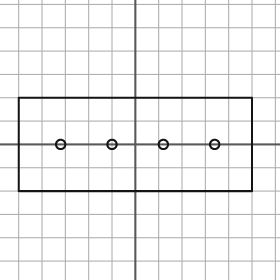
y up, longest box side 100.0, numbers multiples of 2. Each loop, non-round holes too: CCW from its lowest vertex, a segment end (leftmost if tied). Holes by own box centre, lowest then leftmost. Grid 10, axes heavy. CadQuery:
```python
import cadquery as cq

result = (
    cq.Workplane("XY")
    .moveTo(-50.0, -20.0)
    .lineTo(50.0, -20.0)
    .lineTo(50.0, 20.0)
    .lineTo(-50.0, 20.0)
    .close()
    .moveTo(-32.0, 0.0)
    .circle(2.0)
    .moveTo(-10.0, 0.0)
    .circle(2.0)
    .moveTo(12.0, 0.0)
    .circle(2.0)
    .moveTo(34.0, 0.0)
    .circle(2.0)
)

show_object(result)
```